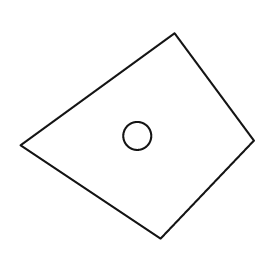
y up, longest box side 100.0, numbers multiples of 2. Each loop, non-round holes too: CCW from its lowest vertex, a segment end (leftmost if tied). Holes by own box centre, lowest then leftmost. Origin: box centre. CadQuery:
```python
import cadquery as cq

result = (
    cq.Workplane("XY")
    .moveTo(10.0, -44.0)
    .lineTo(50.0, -2.0)
    .lineTo(16.0, 44.0)
    .lineTo(-50.0, -4.0)
    .close()
    .moveTo(0.0, 0.0)
    .circle(6.0)
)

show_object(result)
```